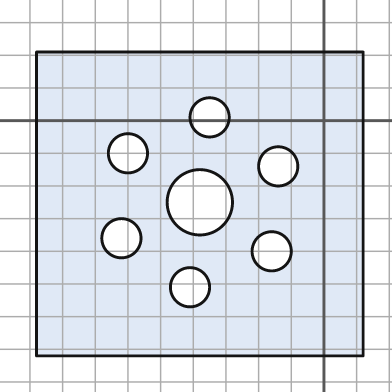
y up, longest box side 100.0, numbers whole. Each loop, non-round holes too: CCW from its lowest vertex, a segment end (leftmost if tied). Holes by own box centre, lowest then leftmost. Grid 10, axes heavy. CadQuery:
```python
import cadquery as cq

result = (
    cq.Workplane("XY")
    .moveTo(-88.0, -72.0)
    .lineTo(12.0, -72.0)
    .lineTo(12.0, 21.0)
    .lineTo(-88.0, 21.0)
    .close()
    .moveTo(-41.0, -51.0)
    .circle(6.0)
    .moveTo(-16.0, -40.0)
    .circle(6.0)
    .moveTo(-62.0, -36.0)
    .circle(6.0)
    .moveTo(-38.0, -25.0)
    .circle(10.0)
    .moveTo(-14.0, -14.0)
    .circle(6.0)
    .moveTo(-60.0, -10.0)
    .circle(6.0)
    .moveTo(-35.0, 1.0)
    .circle(6.0)
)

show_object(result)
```